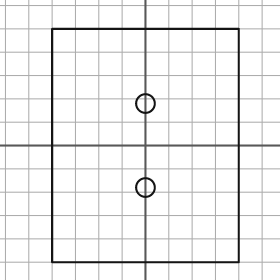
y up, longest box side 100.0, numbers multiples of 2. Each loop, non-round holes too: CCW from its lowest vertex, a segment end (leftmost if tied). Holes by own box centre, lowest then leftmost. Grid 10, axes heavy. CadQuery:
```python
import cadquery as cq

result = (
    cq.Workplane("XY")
    .moveTo(-40.0, -50.0)
    .lineTo(40.0, -50.0)
    .lineTo(40.0, 50.0)
    .lineTo(-40.0, 50.0)
    .close()
    .moveTo(0.0, -18.0)
    .circle(4.0)
    .moveTo(0.0, 18.0)
    .circle(4.0)
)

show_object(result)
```